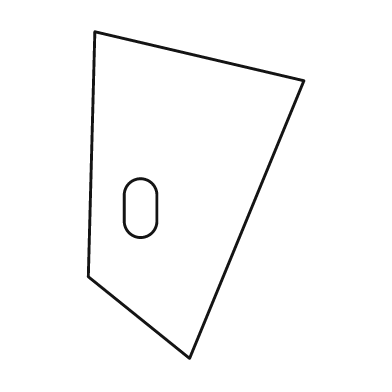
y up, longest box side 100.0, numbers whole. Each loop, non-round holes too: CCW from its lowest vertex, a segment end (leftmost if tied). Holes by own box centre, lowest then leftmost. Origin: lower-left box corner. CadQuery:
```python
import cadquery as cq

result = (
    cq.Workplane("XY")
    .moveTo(31.0, 0.0)
    .lineTo(66.0, 85.0)
    .lineTo(2.0, 100.0)
    .lineTo(0.0, 25.0)
    .close()
    .moveTo(11.0, 42.0)
    .threePointArc((16.0, 37.0), (21.0, 42.0))
    .lineTo(21.0, 50.0)
    .threePointArc((16.0, 55.0), (11.0, 50.0))
    .close()
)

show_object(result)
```